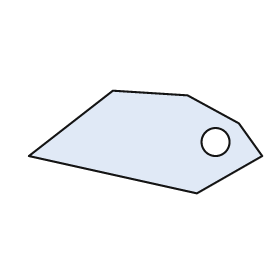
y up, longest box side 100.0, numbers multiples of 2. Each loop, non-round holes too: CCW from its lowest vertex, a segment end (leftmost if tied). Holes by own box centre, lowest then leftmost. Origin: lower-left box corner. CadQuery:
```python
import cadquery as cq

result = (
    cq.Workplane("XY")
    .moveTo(72.0, 0.0)
    .lineTo(100.0, 16.0)
    .lineTo(90.0, 30.0)
    .lineTo(68.0, 42.0)
    .lineTo(36.0, 44.0)
    .lineTo(0.0, 16.0)
    .close()
    .moveTo(80.0, 22.0)
    .circle(6.0)
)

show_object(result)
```